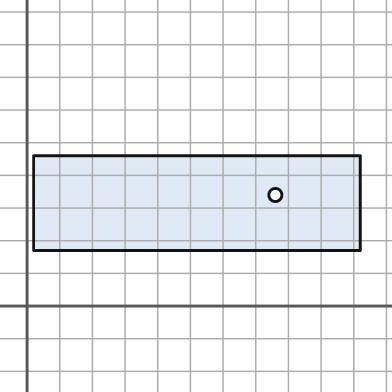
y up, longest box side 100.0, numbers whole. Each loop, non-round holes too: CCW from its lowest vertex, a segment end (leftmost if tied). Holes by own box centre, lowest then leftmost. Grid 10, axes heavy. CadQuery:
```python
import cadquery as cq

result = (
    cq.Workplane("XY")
    .moveTo(2.0, 17.0)
    .lineTo(102.0, 17.0)
    .lineTo(102.0, 46.0)
    .lineTo(2.0, 46.0)
    .close()
    .moveTo(76.0, 34.0)
    .circle(2.0)
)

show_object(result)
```